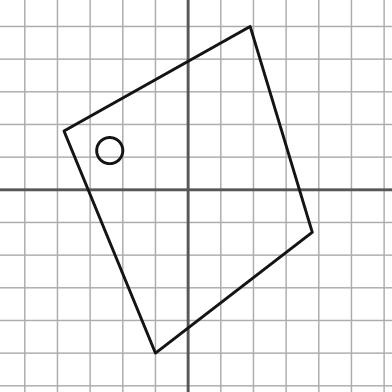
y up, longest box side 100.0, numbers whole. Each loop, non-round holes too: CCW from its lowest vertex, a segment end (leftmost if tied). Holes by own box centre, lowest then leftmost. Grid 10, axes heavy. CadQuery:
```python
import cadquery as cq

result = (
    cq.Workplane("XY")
    .moveTo(-10.0, -50.0)
    .lineTo(38.0, -13.0)
    .lineTo(19.0, 50.0)
    .lineTo(-38.0, 18.0)
    .close()
    .moveTo(-24.0, 12.0)
    .circle(4.0)
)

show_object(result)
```